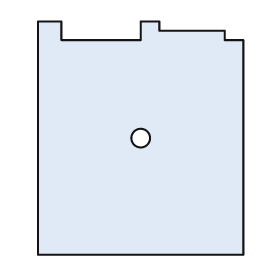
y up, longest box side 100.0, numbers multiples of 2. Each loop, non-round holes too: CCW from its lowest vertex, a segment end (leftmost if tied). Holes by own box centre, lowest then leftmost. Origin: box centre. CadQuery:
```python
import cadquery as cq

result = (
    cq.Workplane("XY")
    .moveTo(-44.0, -50.0)
    .lineTo(44.0, -50.0)
    .lineTo(44.0, 42.0)
    .lineTo(36.0, 42.0)
    .lineTo(36.0, 46.0)
    .lineTo(8.0, 46.0)
    .lineTo(8.0, 50.0)
    .lineTo(0.0, 50.0)
    .lineTo(0.0, 42.0)
    .lineTo(-34.0, 42.0)
    .lineTo(-34.0, 50.0)
    .lineTo(-44.0, 50.0)
    .close()
    .moveTo(0.0, 0.0)
    .circle(4.0)
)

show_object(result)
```